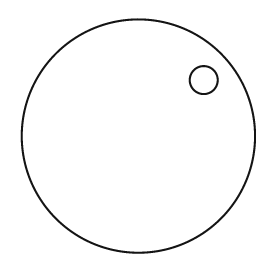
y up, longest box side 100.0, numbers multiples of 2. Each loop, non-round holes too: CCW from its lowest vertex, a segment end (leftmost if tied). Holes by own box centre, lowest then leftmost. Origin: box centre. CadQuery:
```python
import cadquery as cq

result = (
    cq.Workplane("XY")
    .moveTo(0.0, 0.0)
    .circle(50.0)
    .moveTo(28.0, 24.0)
    .circle(6.0)
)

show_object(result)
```